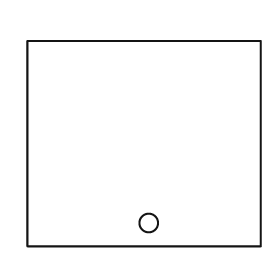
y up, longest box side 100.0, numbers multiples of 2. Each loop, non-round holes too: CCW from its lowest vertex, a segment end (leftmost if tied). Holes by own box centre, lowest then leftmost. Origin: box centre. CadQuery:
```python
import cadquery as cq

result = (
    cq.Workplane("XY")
    .moveTo(-50.0, -44.0)
    .lineTo(50.0, -44.0)
    .lineTo(50.0, 44.0)
    .lineTo(-50.0, 44.0)
    .close()
    .moveTo(2.0, -34.0)
    .circle(4.0)
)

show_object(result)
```